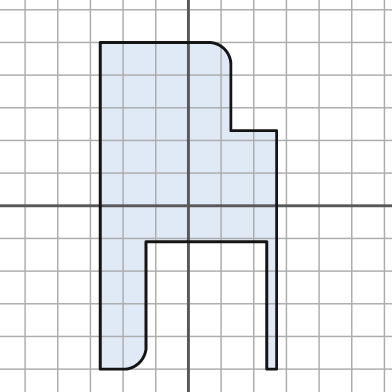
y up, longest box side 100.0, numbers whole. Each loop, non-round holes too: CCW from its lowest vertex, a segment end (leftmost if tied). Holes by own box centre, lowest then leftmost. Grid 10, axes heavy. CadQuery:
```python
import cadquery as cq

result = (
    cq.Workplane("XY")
    .moveTo(-27.0, -50.0)
    .lineTo(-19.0, -50.0)
    .threePointArc((-15.0, -48.0), (-13.0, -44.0))
    .lineTo(-13.0, -11.0)
    .lineTo(24.0, -11.0)
    .lineTo(24.0, -50.0)
    .lineTo(27.0, -50.0)
    .lineTo(27.0, 23.0)
    .lineTo(13.0, 23.0)
    .lineTo(13.0, 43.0)
    .threePointArc((11.0, 48.0), (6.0, 50.0))
    .lineTo(-27.0, 50.0)
    .close()
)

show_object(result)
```